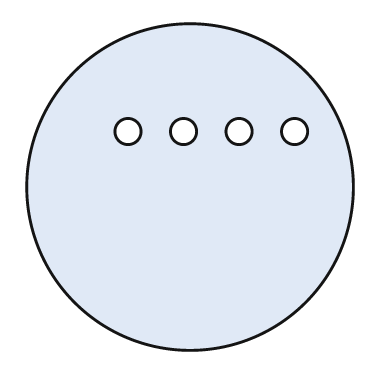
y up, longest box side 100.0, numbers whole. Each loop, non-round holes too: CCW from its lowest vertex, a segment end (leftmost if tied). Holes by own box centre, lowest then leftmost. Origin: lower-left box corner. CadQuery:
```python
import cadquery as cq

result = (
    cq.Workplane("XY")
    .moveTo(50.0, 50.0)
    .circle(50.0)
    .moveTo(31.0, 67.0)
    .circle(4.0)
    .moveTo(48.0, 67.0)
    .circle(4.0)
    .moveTo(65.0, 67.0)
    .circle(4.0)
    .moveTo(82.0, 67.0)
    .circle(4.0)
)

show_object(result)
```